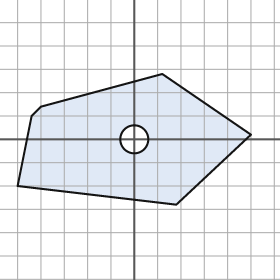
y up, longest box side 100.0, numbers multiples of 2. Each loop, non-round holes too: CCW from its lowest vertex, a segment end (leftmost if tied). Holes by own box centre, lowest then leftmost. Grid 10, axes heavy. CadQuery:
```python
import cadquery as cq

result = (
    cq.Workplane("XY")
    .moveTo(18.0, -28.0)
    .lineTo(50.0, 2.0)
    .lineTo(12.0, 28.0)
    .lineTo(-40.0, 14.0)
    .lineTo(-44.0, 10.0)
    .lineTo(-50.0, -20.0)
    .close()
    .moveTo(0.0, 0.0)
    .circle(6.0)
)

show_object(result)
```